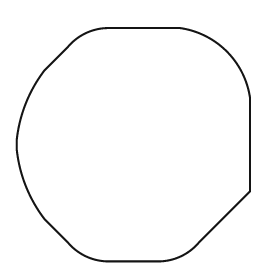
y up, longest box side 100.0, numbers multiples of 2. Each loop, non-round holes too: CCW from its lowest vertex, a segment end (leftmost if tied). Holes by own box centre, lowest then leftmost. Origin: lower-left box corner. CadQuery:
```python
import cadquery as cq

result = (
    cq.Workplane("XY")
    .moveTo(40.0, 0.0)
    .lineTo(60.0, 0.0)
    .threePointArc((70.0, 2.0), (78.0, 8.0))
    .lineTo(100.0, 30.0)
    .lineTo(100.0, 70.0)
    .threePointArc((90.0, 90.0), (70.0, 100.0))
    .lineTo(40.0, 100.0)
    .threePointArc((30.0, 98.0), (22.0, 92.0))
    .lineTo(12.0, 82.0)
    .threePointArc((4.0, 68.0), (0.0, 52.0))
    .lineTo(0.0, 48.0)
    .threePointArc((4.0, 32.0), (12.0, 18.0))
    .lineTo(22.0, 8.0)
    .threePointArc((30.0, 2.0), (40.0, 0.0))
    .close()
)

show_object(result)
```